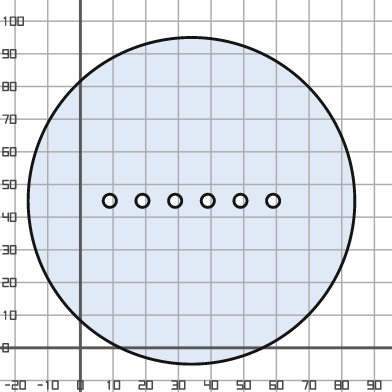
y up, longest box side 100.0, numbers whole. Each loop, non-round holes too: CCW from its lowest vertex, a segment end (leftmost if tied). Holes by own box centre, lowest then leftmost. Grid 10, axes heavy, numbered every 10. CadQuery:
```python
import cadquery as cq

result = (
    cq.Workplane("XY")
    .moveTo(34.0, 45.0)
    .circle(50.0)
    .moveTo(9.0, 45.0)
    .circle(2.0)
    .moveTo(19.0, 45.0)
    .circle(2.0)
    .moveTo(29.0, 45.0)
    .circle(2.0)
    .moveTo(39.0, 45.0)
    .circle(2.0)
    .moveTo(49.0, 45.0)
    .circle(2.0)
    .moveTo(59.0, 45.0)
    .circle(2.0)
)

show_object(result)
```